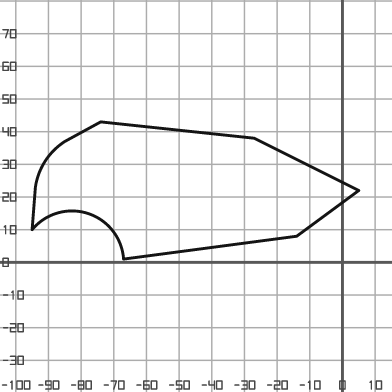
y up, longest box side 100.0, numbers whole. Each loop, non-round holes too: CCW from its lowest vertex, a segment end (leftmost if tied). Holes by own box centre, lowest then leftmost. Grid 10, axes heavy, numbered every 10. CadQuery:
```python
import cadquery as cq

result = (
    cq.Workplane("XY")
    .moveTo(-67.0, 1.0)
    .lineTo(-14.0, 8.0)
    .lineTo(5.0, 22.0)
    .lineTo(-27.0, 38.0)
    .lineTo(-74.0, 43.0)
    .lineTo(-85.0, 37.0)
    .threePointArc((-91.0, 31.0), (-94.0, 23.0))
    .lineTo(-95.0, 10.0)
    .threePointArc((-78.0, 15.0), (-67.0, 1.0))
    .close()
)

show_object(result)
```